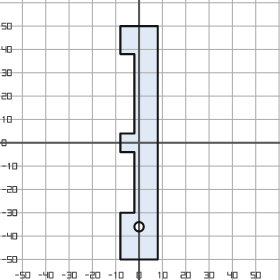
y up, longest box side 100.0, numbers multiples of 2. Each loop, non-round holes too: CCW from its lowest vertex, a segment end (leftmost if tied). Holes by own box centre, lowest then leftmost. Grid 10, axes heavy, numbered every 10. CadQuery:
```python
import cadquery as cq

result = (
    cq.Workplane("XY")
    .moveTo(-8.0, -50.0)
    .lineTo(8.0, -50.0)
    .lineTo(8.0, 50.0)
    .lineTo(-8.0, 50.0)
    .lineTo(-8.0, 38.0)
    .lineTo(-2.0, 38.0)
    .lineTo(-2.0, 4.0)
    .lineTo(-8.0, 4.0)
    .lineTo(-8.0, -4.0)
    .lineTo(-2.0, -4.0)
    .lineTo(-2.0, -30.0)
    .lineTo(-8.0, -30.0)
    .close()
    .moveTo(0.0, -36.0)
    .circle(2.0)
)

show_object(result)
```